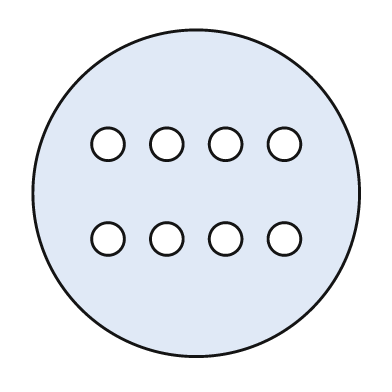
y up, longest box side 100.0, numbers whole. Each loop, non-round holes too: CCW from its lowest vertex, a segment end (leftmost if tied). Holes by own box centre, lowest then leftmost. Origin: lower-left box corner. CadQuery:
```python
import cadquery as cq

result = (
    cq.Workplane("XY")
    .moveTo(50.0, 50.0)
    .circle(50.0)
    .moveTo(23.0, 36.0)
    .circle(5.0)
    .moveTo(41.0, 36.0)
    .circle(5.0)
    .moveTo(59.0, 36.0)
    .circle(5.0)
    .moveTo(77.0, 36.0)
    .circle(5.0)
    .moveTo(23.0, 65.0)
    .circle(5.0)
    .moveTo(41.0, 65.0)
    .circle(5.0)
    .moveTo(59.0, 65.0)
    .circle(5.0)
    .moveTo(77.0, 65.0)
    .circle(5.0)
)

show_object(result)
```